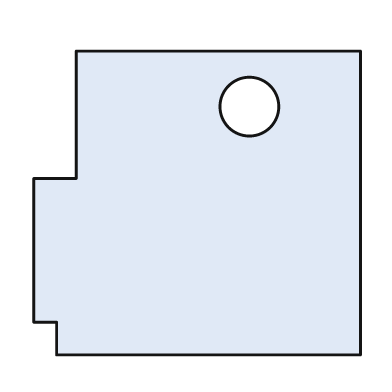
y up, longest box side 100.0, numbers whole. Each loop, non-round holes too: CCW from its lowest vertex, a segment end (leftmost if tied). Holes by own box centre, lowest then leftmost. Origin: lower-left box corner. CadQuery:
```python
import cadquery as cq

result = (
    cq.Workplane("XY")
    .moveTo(7.0, 0.0)
    .lineTo(100.0, 0.0)
    .lineTo(100.0, 93.0)
    .lineTo(13.0, 93.0)
    .lineTo(13.0, 54.0)
    .lineTo(0.0, 54.0)
    .lineTo(0.0, 10.0)
    .lineTo(7.0, 10.0)
    .close()
    .moveTo(66.0, 76.0)
    .circle(9.0)
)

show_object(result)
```